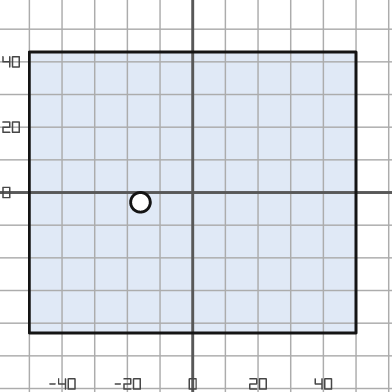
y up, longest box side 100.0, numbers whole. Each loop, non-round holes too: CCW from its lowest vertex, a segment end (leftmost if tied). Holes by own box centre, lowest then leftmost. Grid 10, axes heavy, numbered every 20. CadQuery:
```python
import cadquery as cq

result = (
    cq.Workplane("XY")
    .moveTo(-50.0, -43.0)
    .lineTo(50.0, -43.0)
    .lineTo(50.0, 43.0)
    .lineTo(-50.0, 43.0)
    .close()
    .moveTo(-16.0, -3.0)
    .circle(3.0)
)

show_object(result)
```